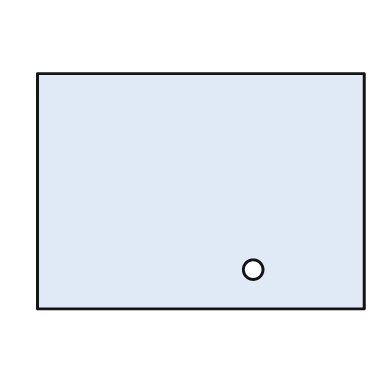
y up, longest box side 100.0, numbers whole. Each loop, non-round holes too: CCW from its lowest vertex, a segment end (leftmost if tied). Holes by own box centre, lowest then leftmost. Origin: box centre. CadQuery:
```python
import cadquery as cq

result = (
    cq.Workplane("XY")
    .moveTo(-50.0, -36.0)
    .lineTo(50.0, -36.0)
    .lineTo(50.0, 36.0)
    .lineTo(-50.0, 36.0)
    .close()
    .moveTo(16.0, -24.0)
    .circle(3.0)
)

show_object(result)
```